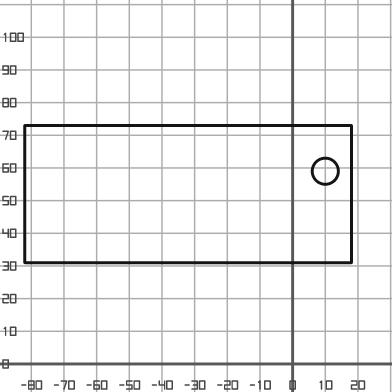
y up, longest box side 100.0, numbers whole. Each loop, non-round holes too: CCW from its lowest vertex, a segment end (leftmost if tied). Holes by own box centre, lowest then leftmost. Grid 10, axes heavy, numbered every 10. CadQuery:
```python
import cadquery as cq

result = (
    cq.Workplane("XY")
    .moveTo(-82.0, 31.0)
    .lineTo(18.0, 31.0)
    .lineTo(18.0, 73.0)
    .lineTo(-82.0, 73.0)
    .close()
    .moveTo(10.0, 59.0)
    .circle(4.0)
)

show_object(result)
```